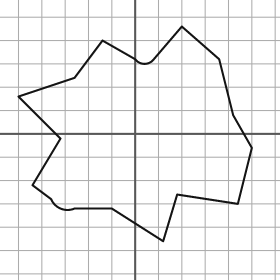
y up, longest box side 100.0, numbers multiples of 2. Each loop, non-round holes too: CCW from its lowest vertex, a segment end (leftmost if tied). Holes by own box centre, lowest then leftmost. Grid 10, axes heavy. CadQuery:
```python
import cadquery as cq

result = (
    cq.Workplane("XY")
    .moveTo(12.0, -46.0)
    .lineTo(18.0, -26.0)
    .lineTo(44.0, -30.0)
    .lineTo(50.0, -6.0)
    .lineTo(42.0, 8.0)
    .lineTo(36.0, 32.0)
    .lineTo(20.0, 46.0)
    .lineTo(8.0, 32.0)
    .threePointArc((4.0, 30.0), (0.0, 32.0))
    .lineTo(-14.0, 40.0)
    .lineTo(-26.0, 24.0)
    .lineTo(-50.0, 16.0)
    .lineTo(-32.0, -2.0)
    .lineTo(-44.0, -22.0)
    .lineTo(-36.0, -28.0)
    .threePointArc((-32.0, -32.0), (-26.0, -32.0))
    .lineTo(-10.0, -32.0)
    .close()
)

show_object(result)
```